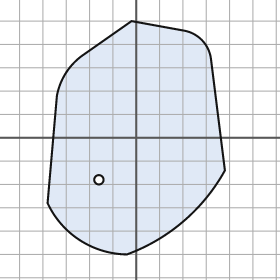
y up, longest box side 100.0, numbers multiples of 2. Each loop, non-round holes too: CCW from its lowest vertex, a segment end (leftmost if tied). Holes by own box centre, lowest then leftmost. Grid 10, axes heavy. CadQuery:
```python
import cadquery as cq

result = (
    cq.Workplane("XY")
    .moveTo(-4.0, -50.0)
    .threePointArc((20.0, -36.0), (38.0, -14.0))
    .lineTo(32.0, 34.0)
    .threePointArc((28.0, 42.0), (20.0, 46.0))
    .lineTo(-2.0, 50.0)
    .lineTo(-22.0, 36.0)
    .threePointArc((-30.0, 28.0), (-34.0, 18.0))
    .lineTo(-38.0, -28.0)
    .threePointArc((-24.0, -44.0), (-4.0, -50.0))
    .close()
    .moveTo(-16.0, -18.0)
    .circle(2.0)
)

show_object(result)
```